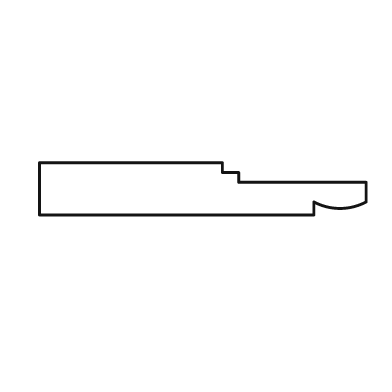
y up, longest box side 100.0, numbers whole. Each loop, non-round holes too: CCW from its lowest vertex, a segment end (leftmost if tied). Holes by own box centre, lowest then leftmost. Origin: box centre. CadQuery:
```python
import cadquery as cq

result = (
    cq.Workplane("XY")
    .moveTo(-50.0, -8.0)
    .lineTo(34.0, -8.0)
    .lineTo(34.0, -4.0)
    .threePointArc((42.0, -6.0), (50.0, -4.0))
    .lineTo(50.0, 2.0)
    .lineTo(11.0, 2.0)
    .lineTo(11.0, 5.0)
    .lineTo(6.0, 5.0)
    .lineTo(6.0, 8.0)
    .lineTo(-50.0, 8.0)
    .close()
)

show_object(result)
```